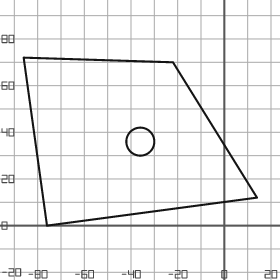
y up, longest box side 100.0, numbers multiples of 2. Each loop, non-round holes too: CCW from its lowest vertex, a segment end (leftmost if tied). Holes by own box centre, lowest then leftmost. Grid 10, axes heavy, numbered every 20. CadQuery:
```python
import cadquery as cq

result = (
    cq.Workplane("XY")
    .moveTo(-76.0, 0.0)
    .lineTo(14.0, 12.0)
    .lineTo(-22.0, 70.0)
    .lineTo(-86.0, 72.0)
    .close()
    .moveTo(-36.0, 36.0)
    .circle(6.0)
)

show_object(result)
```